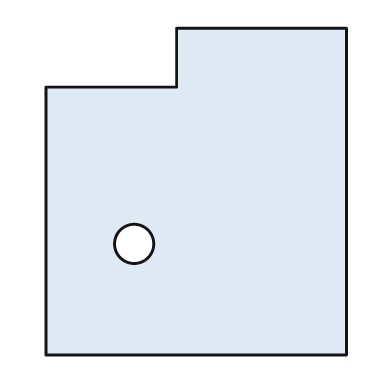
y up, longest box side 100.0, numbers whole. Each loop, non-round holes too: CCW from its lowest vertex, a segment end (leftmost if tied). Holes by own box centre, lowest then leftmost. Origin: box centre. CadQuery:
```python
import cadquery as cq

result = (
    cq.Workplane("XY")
    .moveTo(-46.0, -50.0)
    .lineTo(46.0, -50.0)
    .lineTo(46.0, 50.0)
    .lineTo(-6.0, 50.0)
    .lineTo(-6.0, 32.0)
    .lineTo(-46.0, 32.0)
    .close()
    .moveTo(-19.0, -16.0)
    .circle(6.0)
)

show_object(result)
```